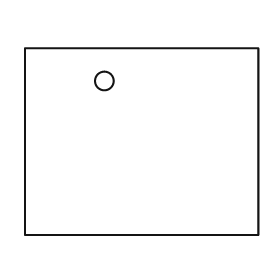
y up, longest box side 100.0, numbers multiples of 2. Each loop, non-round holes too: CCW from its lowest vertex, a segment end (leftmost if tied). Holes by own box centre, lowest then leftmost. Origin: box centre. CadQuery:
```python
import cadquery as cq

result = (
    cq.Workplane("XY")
    .moveTo(-50.0, -40.0)
    .lineTo(50.0, -40.0)
    .lineTo(50.0, 40.0)
    .lineTo(-50.0, 40.0)
    .close()
    .moveTo(-16.0, 26.0)
    .circle(4.0)
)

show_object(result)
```